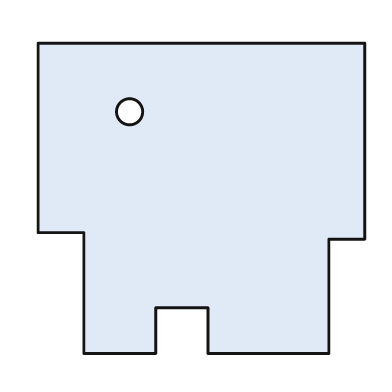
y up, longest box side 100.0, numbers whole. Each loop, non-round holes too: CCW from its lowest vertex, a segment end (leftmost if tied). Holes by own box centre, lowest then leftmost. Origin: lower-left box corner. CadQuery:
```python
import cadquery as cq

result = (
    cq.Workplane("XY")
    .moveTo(14.0, 0.0)
    .lineTo(36.0, 0.0)
    .lineTo(36.0, 14.0)
    .lineTo(52.0, 14.0)
    .lineTo(52.0, 0.0)
    .lineTo(89.0, 0.0)
    .lineTo(89.0, 35.0)
    .lineTo(100.0, 35.0)
    .lineTo(100.0, 95.0)
    .lineTo(0.0, 95.0)
    .lineTo(0.0, 37.0)
    .lineTo(14.0, 37.0)
    .close()
    .moveTo(28.0, 74.0)
    .circle(4.0)
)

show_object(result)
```